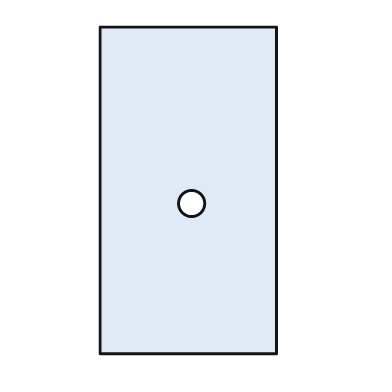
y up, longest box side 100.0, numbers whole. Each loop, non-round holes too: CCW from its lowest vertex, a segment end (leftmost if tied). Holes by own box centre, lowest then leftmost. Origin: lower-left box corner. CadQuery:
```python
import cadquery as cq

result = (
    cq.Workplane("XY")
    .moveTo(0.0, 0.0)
    .lineTo(54.0, 0.0)
    .lineTo(54.0, 100.0)
    .lineTo(0.0, 100.0)
    .close()
    .moveTo(28.0, 46.0)
    .circle(4.0)
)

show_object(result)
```